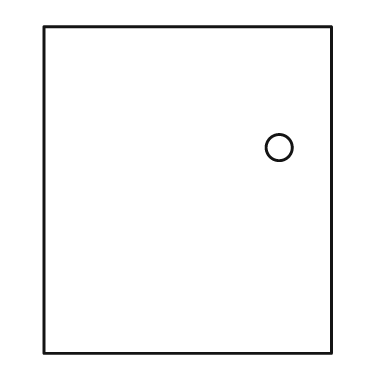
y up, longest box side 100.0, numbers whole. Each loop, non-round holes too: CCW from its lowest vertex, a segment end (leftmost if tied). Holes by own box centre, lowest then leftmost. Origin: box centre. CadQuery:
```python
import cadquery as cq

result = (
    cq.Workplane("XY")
    .moveTo(-44.0, -50.0)
    .lineTo(44.0, -50.0)
    .lineTo(44.0, 50.0)
    .lineTo(-44.0, 50.0)
    .close()
    .moveTo(28.0, 13.0)
    .circle(4.0)
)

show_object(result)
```